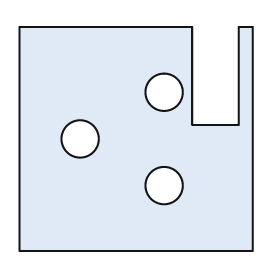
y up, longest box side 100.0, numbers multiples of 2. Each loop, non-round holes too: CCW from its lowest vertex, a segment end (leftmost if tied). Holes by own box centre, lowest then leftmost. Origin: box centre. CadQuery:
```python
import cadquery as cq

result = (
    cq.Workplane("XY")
    .moveTo(-50.0, -48.0)
    .lineTo(50.0, -48.0)
    .lineTo(50.0, 48.0)
    .lineTo(44.0, 48.0)
    .lineTo(44.0, 6.0)
    .lineTo(24.0, 6.0)
    .lineTo(24.0, 48.0)
    .lineTo(-50.0, 48.0)
    .close()
    .moveTo(12.0, -20.0)
    .circle(8.0)
    .moveTo(-24.0, 0.0)
    .circle(8.0)
    .moveTo(12.0, 20.0)
    .circle(8.0)
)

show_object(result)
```